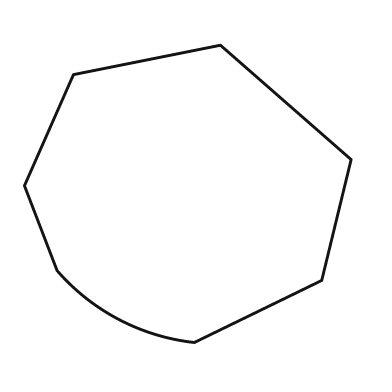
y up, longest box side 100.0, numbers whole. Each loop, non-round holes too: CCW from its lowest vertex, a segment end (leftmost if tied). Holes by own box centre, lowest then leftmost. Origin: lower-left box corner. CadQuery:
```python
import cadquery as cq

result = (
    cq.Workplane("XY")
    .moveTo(52.0, 0.0)
    .lineTo(91.0, 19.0)
    .lineTo(100.0, 56.0)
    .lineTo(60.0, 91.0)
    .lineTo(15.0, 82.0)
    .lineTo(0.0, 48.0)
    .lineTo(10.0, 22.0)
    .threePointArc((29.0, 7.0), (52.0, 0.0))
    .close()
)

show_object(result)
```